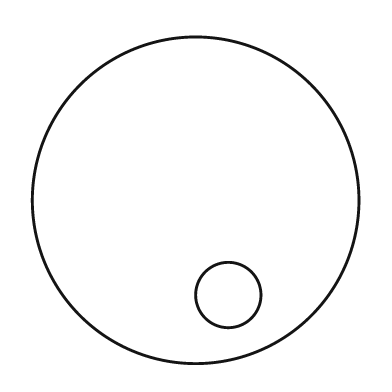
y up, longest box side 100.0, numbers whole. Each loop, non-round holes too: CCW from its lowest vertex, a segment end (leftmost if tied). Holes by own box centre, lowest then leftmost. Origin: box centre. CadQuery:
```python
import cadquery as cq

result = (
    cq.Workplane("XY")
    .moveTo(0.0, 0.0)
    .circle(50.0)
    .moveTo(10.0, -29.0)
    .circle(10.0)
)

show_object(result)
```